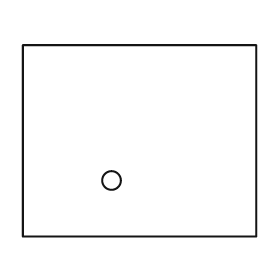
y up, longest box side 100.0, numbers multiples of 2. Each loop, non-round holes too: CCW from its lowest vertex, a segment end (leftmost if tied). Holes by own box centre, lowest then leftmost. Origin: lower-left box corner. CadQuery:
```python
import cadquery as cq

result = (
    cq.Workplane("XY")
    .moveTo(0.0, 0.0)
    .lineTo(100.0, 0.0)
    .lineTo(100.0, 82.0)
    .lineTo(0.0, 82.0)
    .close()
    .moveTo(38.0, 24.0)
    .circle(4.0)
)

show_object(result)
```